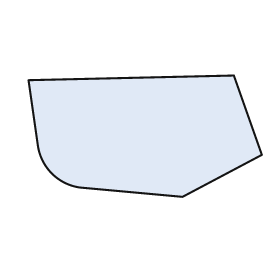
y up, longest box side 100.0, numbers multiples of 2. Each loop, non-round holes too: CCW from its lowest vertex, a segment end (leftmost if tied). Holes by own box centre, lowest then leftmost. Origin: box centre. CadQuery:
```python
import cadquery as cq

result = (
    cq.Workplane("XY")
    .moveTo(16.0, -26.0)
    .lineTo(50.0, -8.0)
    .lineTo(38.0, 26.0)
    .lineTo(-50.0, 24.0)
    .lineTo(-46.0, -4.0)
    .threePointArc((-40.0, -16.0), (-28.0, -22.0))
    .close()
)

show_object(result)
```